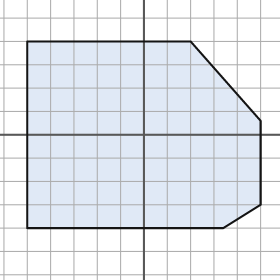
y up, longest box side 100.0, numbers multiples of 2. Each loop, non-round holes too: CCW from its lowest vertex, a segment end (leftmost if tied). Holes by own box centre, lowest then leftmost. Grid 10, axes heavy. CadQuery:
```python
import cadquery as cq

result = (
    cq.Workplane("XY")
    .moveTo(-50.0, -40.0)
    .lineTo(34.0, -40.0)
    .lineTo(50.0, -30.0)
    .lineTo(50.0, 6.0)
    .lineTo(20.0, 40.0)
    .lineTo(-50.0, 40.0)
    .close()
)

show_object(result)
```